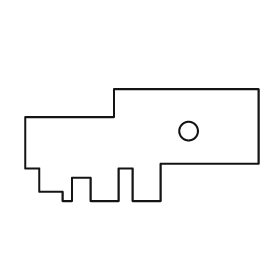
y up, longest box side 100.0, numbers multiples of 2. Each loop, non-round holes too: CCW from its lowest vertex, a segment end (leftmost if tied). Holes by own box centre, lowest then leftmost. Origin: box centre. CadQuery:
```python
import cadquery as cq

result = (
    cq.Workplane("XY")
    .moveTo(-34.0, -24.0)
    .lineTo(-30.0, -24.0)
    .lineTo(-30.0, -14.0)
    .lineTo(-22.0, -14.0)
    .lineTo(-22.0, -24.0)
    .lineTo(-10.0, -24.0)
    .lineTo(-10.0, -10.0)
    .lineTo(-4.0, -10.0)
    .lineTo(-4.0, -24.0)
    .lineTo(8.0, -24.0)
    .lineTo(8.0, -8.0)
    .lineTo(50.0, -8.0)
    .lineTo(50.0, 24.0)
    .lineTo(-12.0, 24.0)
    .lineTo(-12.0, 12.0)
    .lineTo(-50.0, 12.0)
    .lineTo(-50.0, -10.0)
    .lineTo(-44.0, -10.0)
    .lineTo(-44.0, -20.0)
    .lineTo(-34.0, -20.0)
    .close()
    .moveTo(20.0, 6.0)
    .circle(4.0)
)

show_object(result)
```